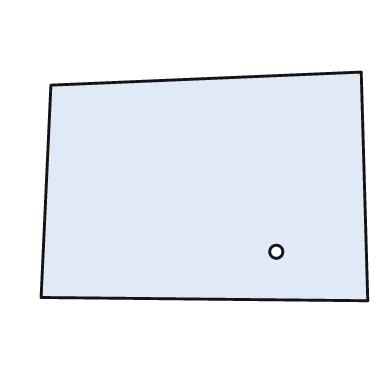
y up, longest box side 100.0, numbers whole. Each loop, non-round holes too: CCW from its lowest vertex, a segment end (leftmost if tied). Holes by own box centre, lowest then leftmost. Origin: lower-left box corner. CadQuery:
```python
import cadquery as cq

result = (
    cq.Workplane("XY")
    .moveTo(100.0, 0.0)
    .lineTo(98.0, 70.0)
    .lineTo(3.0, 66.0)
    .lineTo(0.0, 1.0)
    .close()
    .moveTo(72.0, 15.0)
    .circle(2.0)
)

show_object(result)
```